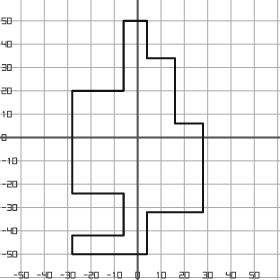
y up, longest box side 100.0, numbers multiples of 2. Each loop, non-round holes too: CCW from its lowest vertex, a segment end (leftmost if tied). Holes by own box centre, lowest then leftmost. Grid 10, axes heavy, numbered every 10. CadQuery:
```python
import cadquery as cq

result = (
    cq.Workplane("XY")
    .moveTo(-28.0, -50.0)
    .lineTo(4.0, -50.0)
    .lineTo(4.0, -32.0)
    .lineTo(28.0, -32.0)
    .lineTo(28.0, 6.0)
    .lineTo(16.0, 6.0)
    .lineTo(16.0, 34.0)
    .lineTo(4.0, 34.0)
    .lineTo(4.0, 50.0)
    .lineTo(-6.0, 50.0)
    .lineTo(-6.0, 20.0)
    .lineTo(-28.0, 20.0)
    .lineTo(-28.0, -24.0)
    .lineTo(-6.0, -24.0)
    .lineTo(-6.0, -42.0)
    .lineTo(-28.0, -42.0)
    .close()
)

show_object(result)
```